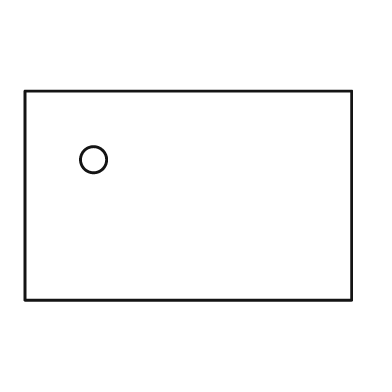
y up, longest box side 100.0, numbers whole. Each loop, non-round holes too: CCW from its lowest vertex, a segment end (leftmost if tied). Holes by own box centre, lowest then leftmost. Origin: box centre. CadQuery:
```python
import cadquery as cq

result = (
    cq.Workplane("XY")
    .moveTo(-50.0, -32.0)
    .lineTo(50.0, -32.0)
    .lineTo(50.0, 32.0)
    .lineTo(-50.0, 32.0)
    .close()
    .moveTo(-29.0, 11.0)
    .circle(4.0)
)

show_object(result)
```